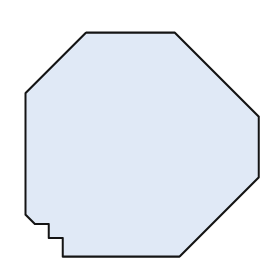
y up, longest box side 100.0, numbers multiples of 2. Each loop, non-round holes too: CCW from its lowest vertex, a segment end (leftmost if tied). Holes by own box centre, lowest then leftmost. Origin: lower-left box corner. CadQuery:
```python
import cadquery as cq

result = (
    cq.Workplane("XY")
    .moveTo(16.0, 0.0)
    .lineTo(66.0, 0.0)
    .lineTo(100.0, 34.0)
    .lineTo(100.0, 60.0)
    .lineTo(64.0, 96.0)
    .lineTo(26.0, 96.0)
    .lineTo(0.0, 70.0)
    .lineTo(0.0, 18.0)
    .lineTo(4.0, 14.0)
    .lineTo(10.0, 14.0)
    .lineTo(10.0, 8.0)
    .lineTo(16.0, 8.0)
    .close()
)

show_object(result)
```